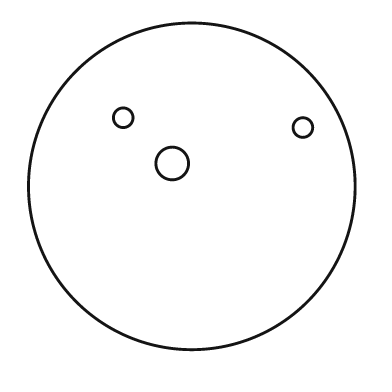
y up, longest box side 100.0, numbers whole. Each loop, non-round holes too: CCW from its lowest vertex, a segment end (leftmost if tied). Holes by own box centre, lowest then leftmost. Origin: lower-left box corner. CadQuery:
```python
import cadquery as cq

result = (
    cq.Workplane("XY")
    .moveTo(50.0, 50.0)
    .circle(50.0)
    .moveTo(44.0, 57.0)
    .circle(5.0)
    .moveTo(84.0, 68.0)
    .circle(3.0)
    .moveTo(29.0, 71.0)
    .circle(3.0)
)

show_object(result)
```